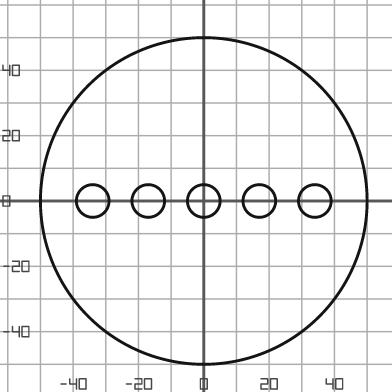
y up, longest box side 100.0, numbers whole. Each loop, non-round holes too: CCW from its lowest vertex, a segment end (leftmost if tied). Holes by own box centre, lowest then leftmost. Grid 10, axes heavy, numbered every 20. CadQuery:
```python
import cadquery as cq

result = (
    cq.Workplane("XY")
    .moveTo(0.0, 0.0)
    .circle(50.0)
    .moveTo(-34.0, 0.0)
    .circle(5.0)
    .moveTo(-17.0, 0.0)
    .circle(5.0)
    .moveTo(0.0, 0.0)
    .circle(5.0)
    .moveTo(17.0, 0.0)
    .circle(5.0)
    .moveTo(34.0, 0.0)
    .circle(5.0)
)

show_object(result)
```